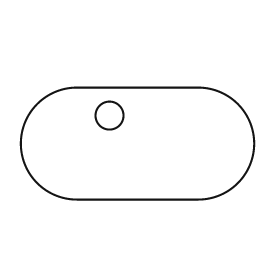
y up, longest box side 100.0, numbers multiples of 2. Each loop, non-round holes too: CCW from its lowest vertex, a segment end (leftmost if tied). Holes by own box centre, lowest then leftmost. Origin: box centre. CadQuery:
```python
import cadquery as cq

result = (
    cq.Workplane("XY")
    .moveTo(-26.0, -24.0)
    .lineTo(26.0, -24.0)
    .threePointArc((50.0, 0.0), (26.0, 24.0))
    .lineTo(-26.0, 24.0)
    .threePointArc((-50.0, 0.0), (-26.0, -24.0))
    .close()
    .moveTo(-12.0, 12.0)
    .circle(6.0)
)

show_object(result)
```